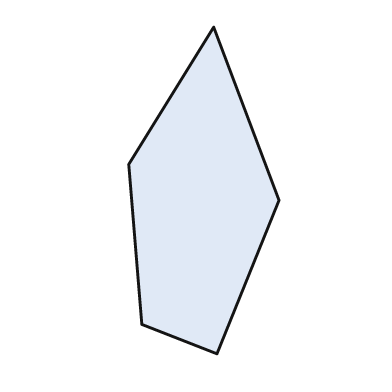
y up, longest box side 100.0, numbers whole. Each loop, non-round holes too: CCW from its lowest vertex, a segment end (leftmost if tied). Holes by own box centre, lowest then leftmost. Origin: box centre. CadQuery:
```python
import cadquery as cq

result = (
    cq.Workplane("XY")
    .moveTo(4.0, -50.0)
    .lineTo(23.0, -3.0)
    .lineTo(3.0, 50.0)
    .lineTo(-23.0, 8.0)
    .lineTo(-19.0, -41.0)
    .close()
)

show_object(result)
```